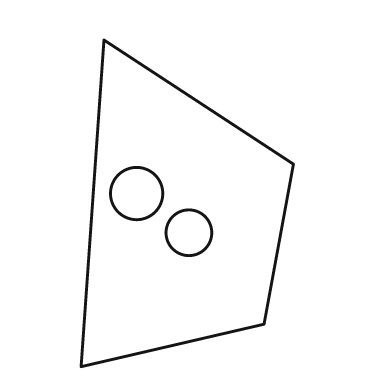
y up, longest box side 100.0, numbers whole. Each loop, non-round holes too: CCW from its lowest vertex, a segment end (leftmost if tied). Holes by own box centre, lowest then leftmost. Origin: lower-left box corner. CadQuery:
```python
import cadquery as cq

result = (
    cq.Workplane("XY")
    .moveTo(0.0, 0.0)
    .lineTo(56.0, 13.0)
    .lineTo(65.0, 62.0)
    .lineTo(7.0, 100.0)
    .close()
    .moveTo(33.0, 41.0)
    .circle(7.0)
    .moveTo(17.0, 53.0)
    .circle(8.0)
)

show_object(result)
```